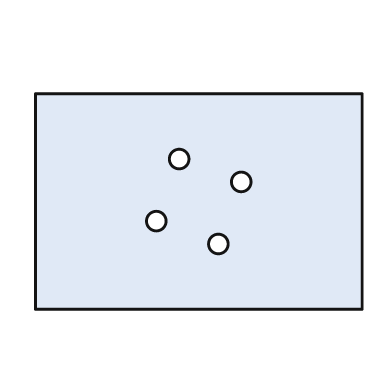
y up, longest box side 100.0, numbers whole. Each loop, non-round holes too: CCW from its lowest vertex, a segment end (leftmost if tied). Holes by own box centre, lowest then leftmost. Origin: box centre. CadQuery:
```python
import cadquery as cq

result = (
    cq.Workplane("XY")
    .moveTo(-50.0, -33.0)
    .lineTo(50.0, -33.0)
    .lineTo(50.0, 33.0)
    .lineTo(-50.0, 33.0)
    .close()
    .moveTo(6.0, -13.0)
    .circle(3.0)
    .moveTo(-13.0, -6.0)
    .circle(3.0)
    .moveTo(13.0, 6.0)
    .circle(3.0)
    .moveTo(-6.0, 13.0)
    .circle(3.0)
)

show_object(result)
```